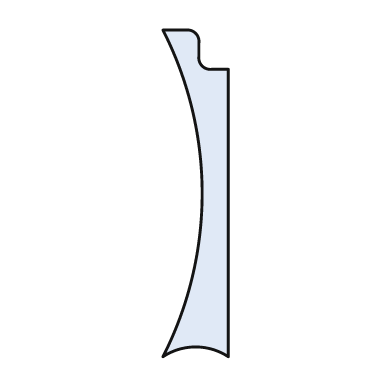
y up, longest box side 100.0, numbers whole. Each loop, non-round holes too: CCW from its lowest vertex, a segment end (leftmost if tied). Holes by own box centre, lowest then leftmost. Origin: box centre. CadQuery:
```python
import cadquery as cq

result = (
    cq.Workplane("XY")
    .moveTo(-10.0, -50.0)
    .threePointArc((0.0, -47.0), (10.0, -50.0))
    .lineTo(10.0, 38.0)
    .lineTo(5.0, 38.0)
    .threePointArc((2.0, 39.0), (1.0, 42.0))
    .lineTo(1.0, 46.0)
    .threePointArc((0.0, 49.0), (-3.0, 50.0))
    .lineTo(-10.0, 50.0)
    .threePointArc((2.0, 0.0), (-10.0, -50.0))
    .close()
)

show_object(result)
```